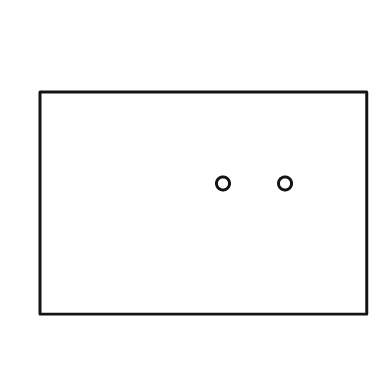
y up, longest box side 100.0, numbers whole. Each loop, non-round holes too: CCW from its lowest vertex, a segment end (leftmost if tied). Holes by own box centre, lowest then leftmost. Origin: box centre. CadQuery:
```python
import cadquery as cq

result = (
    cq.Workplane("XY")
    .moveTo(-50.0, -34.0)
    .lineTo(50.0, -34.0)
    .lineTo(50.0, 34.0)
    .lineTo(-50.0, 34.0)
    .close()
    .moveTo(6.0, 6.0)
    .circle(2.0)
    .moveTo(25.0, 6.0)
    .circle(2.0)
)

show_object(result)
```